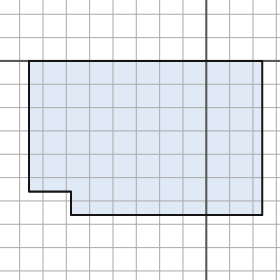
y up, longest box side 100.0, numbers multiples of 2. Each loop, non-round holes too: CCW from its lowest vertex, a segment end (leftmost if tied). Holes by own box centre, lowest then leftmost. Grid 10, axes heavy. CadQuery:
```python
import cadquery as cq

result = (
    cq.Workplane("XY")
    .moveTo(-58.0, -66.0)
    .lineTo(24.0, -66.0)
    .lineTo(24.0, 0.0)
    .lineTo(-76.0, 0.0)
    .lineTo(-76.0, -56.0)
    .lineTo(-58.0, -56.0)
    .close()
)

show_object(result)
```